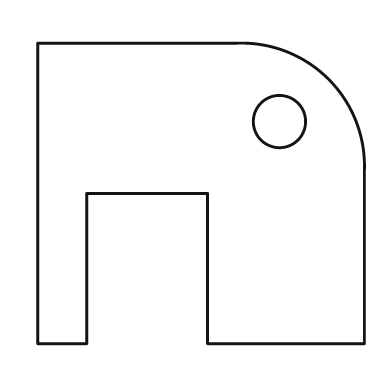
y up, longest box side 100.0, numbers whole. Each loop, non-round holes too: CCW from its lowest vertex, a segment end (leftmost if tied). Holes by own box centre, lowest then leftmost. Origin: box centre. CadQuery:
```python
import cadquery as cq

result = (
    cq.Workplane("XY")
    .moveTo(-50.0, -46.0)
    .lineTo(-35.0, -46.0)
    .lineTo(-35.0, 0.0)
    .lineTo(2.0, 0.0)
    .lineTo(2.0, -46.0)
    .lineTo(50.0, -46.0)
    .lineTo(50.0, 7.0)
    .threePointArc((39.0, 35.0), (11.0, 46.0))
    .lineTo(-50.0, 46.0)
    .close()
    .moveTo(24.0, 22.0)
    .circle(8.0)
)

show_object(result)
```